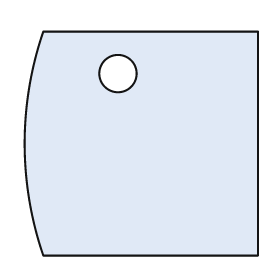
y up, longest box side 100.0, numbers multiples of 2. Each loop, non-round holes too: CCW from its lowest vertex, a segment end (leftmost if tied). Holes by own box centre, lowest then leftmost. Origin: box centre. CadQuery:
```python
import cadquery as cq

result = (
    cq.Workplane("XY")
    .moveTo(-42.0, -48.0)
    .lineTo(50.0, -48.0)
    .lineTo(50.0, 48.0)
    .lineTo(-42.0, 48.0)
    .threePointArc((-50.0, 0.0), (-42.0, -48.0))
    .close()
    .moveTo(-10.0, 30.0)
    .circle(8.0)
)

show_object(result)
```